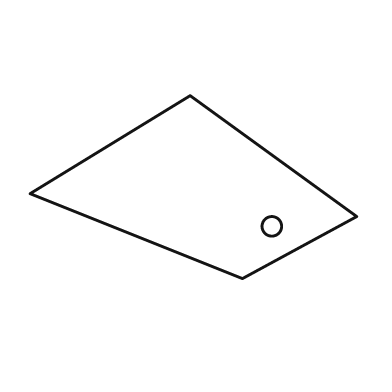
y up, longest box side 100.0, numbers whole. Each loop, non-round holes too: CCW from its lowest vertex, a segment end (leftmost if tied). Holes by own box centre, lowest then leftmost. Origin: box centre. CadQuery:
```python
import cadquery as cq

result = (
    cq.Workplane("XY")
    .moveTo(15.0, -28.0)
    .lineTo(50.0, -9.0)
    .lineTo(-1.0, 28.0)
    .lineTo(-50.0, -2.0)
    .close()
    .moveTo(24.0, -12.0)
    .circle(3.0)
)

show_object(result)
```